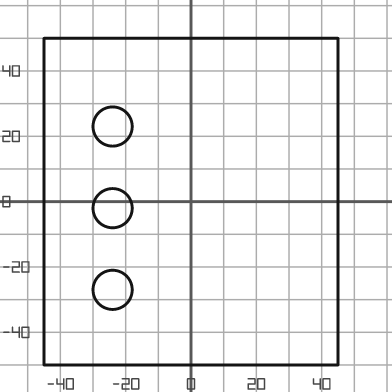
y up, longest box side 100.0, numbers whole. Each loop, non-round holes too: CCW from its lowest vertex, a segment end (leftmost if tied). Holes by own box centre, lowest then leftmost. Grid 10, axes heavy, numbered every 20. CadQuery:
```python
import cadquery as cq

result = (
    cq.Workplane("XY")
    .moveTo(-45.0, -50.0)
    .lineTo(45.0, -50.0)
    .lineTo(45.0, 50.0)
    .lineTo(-45.0, 50.0)
    .close()
    .moveTo(-24.0, -27.0)
    .circle(6.0)
    .moveTo(-24.0, -2.0)
    .circle(6.0)
    .moveTo(-24.0, 23.0)
    .circle(6.0)
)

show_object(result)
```